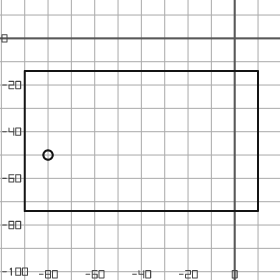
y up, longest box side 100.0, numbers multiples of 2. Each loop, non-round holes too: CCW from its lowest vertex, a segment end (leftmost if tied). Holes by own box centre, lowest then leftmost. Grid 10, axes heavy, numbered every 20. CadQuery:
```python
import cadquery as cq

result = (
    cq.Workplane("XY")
    .moveTo(-90.0, -74.0)
    .lineTo(10.0, -74.0)
    .lineTo(10.0, -14.0)
    .lineTo(-90.0, -14.0)
    .close()
    .moveTo(-80.0, -50.0)
    .circle(2.0)
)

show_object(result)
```